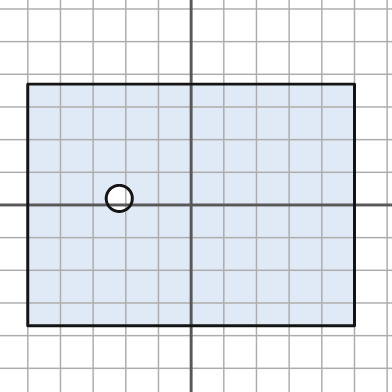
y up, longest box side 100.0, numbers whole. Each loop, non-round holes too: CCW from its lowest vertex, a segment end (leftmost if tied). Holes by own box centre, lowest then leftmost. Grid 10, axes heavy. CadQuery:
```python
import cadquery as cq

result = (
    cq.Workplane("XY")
    .moveTo(-50.0, -37.0)
    .lineTo(50.0, -37.0)
    .lineTo(50.0, 37.0)
    .lineTo(-50.0, 37.0)
    .close()
    .moveTo(-22.0, 2.0)
    .circle(4.0)
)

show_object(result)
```